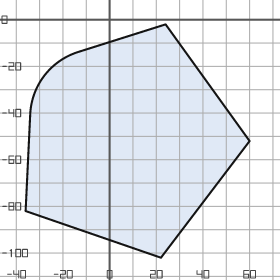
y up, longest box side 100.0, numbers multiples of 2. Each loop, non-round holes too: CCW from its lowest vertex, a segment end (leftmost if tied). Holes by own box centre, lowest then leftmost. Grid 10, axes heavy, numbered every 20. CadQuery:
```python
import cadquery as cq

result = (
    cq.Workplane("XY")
    .moveTo(22.0, -102.0)
    .lineTo(60.0, -52.0)
    .lineTo(24.0, -2.0)
    .lineTo(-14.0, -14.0)
    .threePointArc((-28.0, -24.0), (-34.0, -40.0))
    .lineTo(-36.0, -82.0)
    .close()
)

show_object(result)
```